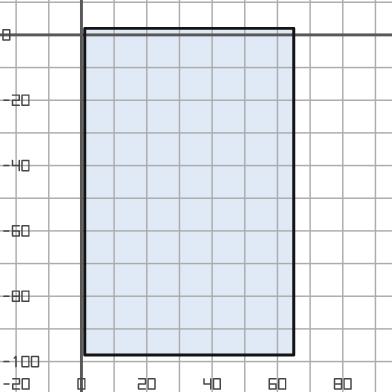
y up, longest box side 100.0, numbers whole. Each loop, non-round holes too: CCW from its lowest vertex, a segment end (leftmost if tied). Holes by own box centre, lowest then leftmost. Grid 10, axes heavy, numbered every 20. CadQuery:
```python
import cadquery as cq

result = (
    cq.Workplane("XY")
    .moveTo(1.0, -98.0)
    .lineTo(65.0, -98.0)
    .lineTo(65.0, 2.0)
    .lineTo(1.0, 2.0)
    .close()
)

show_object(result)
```